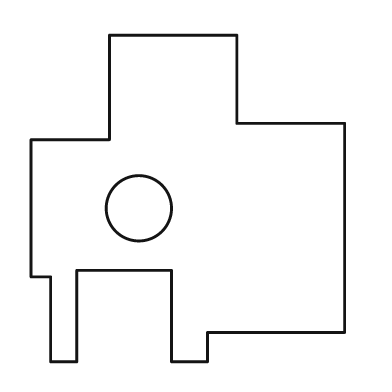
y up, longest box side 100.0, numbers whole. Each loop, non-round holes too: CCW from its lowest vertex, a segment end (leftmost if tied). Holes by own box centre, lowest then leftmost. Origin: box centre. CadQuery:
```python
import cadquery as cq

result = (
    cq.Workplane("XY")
    .moveTo(-42.0, -50.0)
    .lineTo(-34.0, -50.0)
    .lineTo(-34.0, -22.0)
    .lineTo(-5.0, -22.0)
    .lineTo(-5.0, -50.0)
    .lineTo(6.0, -50.0)
    .lineTo(6.0, -41.0)
    .lineTo(48.0, -41.0)
    .lineTo(48.0, 23.0)
    .lineTo(15.0, 23.0)
    .lineTo(15.0, 50.0)
    .lineTo(-24.0, 50.0)
    .lineTo(-24.0, 18.0)
    .lineTo(-48.0, 18.0)
    .lineTo(-48.0, -24.0)
    .lineTo(-42.0, -24.0)
    .close()
    .moveTo(-15.0, -3.0)
    .circle(10.0)
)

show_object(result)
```